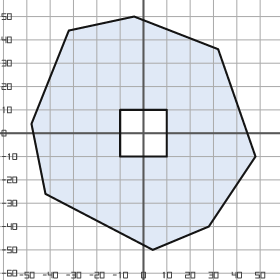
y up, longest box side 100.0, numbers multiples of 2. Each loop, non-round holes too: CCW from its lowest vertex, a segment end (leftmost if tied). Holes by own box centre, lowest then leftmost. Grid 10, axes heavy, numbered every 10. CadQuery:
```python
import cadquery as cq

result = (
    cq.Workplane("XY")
    .moveTo(4.0, -50.0)
    .lineTo(28.0, -40.0)
    .lineTo(48.0, -10.0)
    .lineTo(32.0, 36.0)
    .lineTo(-4.0, 50.0)
    .lineTo(-32.0, 44.0)
    .lineTo(-48.0, 4.0)
    .lineTo(-42.0, -26.0)
    .close()
    .moveTo(-10.0, -10.0)
    .lineTo(10.0, -10.0)
    .lineTo(10.0, 10.0)
    .lineTo(-10.0, 10.0)
    .close()
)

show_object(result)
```